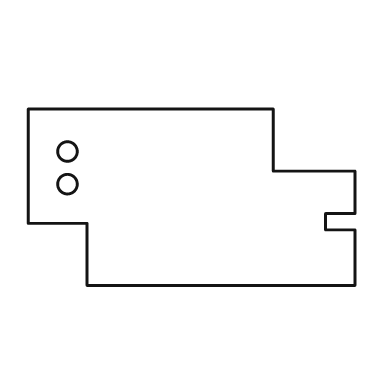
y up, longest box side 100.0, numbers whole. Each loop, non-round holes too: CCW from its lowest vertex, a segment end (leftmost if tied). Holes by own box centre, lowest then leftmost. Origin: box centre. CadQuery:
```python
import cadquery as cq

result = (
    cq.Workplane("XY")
    .moveTo(-32.0, -27.0)
    .lineTo(50.0, -27.0)
    .lineTo(50.0, -10.0)
    .lineTo(41.0, -10.0)
    .lineTo(41.0, -5.0)
    .lineTo(50.0, -5.0)
    .lineTo(50.0, 8.0)
    .lineTo(25.0, 8.0)
    .lineTo(25.0, 27.0)
    .lineTo(-50.0, 27.0)
    .lineTo(-50.0, -8.0)
    .lineTo(-32.0, -8.0)
    .close()
    .moveTo(-38.0, 4.0)
    .circle(3.0)
    .moveTo(-38.0, 14.0)
    .circle(3.0)
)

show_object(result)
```